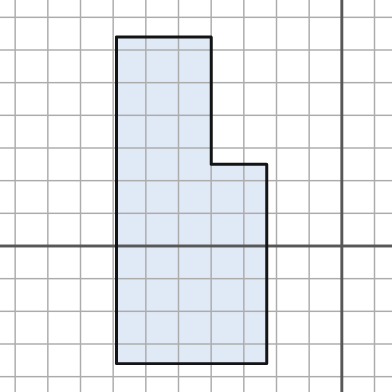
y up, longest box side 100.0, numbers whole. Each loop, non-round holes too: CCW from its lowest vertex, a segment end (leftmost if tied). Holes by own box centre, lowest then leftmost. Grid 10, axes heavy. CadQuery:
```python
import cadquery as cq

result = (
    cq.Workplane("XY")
    .moveTo(-69.0, -36.0)
    .lineTo(-23.0, -36.0)
    .lineTo(-23.0, 25.0)
    .lineTo(-40.0, 25.0)
    .lineTo(-40.0, 64.0)
    .lineTo(-69.0, 64.0)
    .close()
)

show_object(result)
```